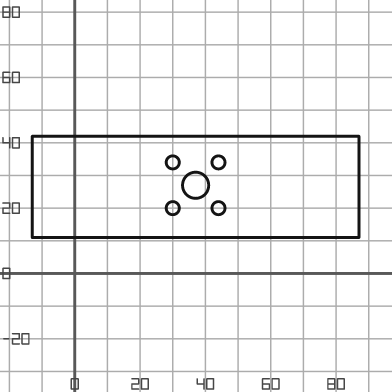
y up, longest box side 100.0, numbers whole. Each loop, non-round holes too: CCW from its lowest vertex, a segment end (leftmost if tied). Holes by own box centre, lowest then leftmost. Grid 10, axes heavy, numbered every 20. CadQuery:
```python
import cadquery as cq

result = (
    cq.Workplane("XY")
    .moveTo(-13.0, 11.0)
    .lineTo(87.0, 11.0)
    .lineTo(87.0, 42.0)
    .lineTo(-13.0, 42.0)
    .close()
    .moveTo(30.0, 20.0)
    .circle(2.0)
    .moveTo(44.0, 20.0)
    .circle(2.0)
    .moveTo(37.0, 27.0)
    .circle(4.0)
    .moveTo(30.0, 34.0)
    .circle(2.0)
    .moveTo(44.0, 34.0)
    .circle(2.0)
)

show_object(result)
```